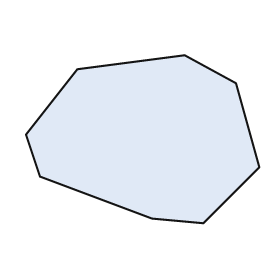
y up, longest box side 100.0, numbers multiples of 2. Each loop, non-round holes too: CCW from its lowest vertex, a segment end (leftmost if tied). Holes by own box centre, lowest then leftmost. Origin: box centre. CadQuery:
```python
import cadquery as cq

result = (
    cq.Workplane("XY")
    .moveTo(26.0, -36.0)
    .lineTo(50.0, -12.0)
    .lineTo(40.0, 24.0)
    .lineTo(18.0, 36.0)
    .lineTo(-28.0, 30.0)
    .lineTo(-50.0, 2.0)
    .lineTo(-44.0, -16.0)
    .lineTo(4.0, -34.0)
    .close()
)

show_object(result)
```